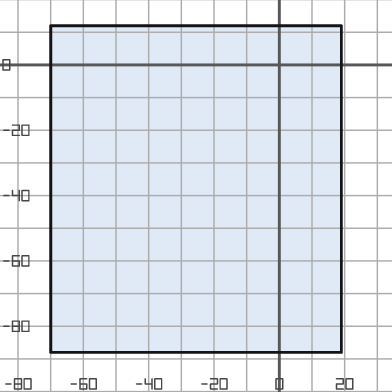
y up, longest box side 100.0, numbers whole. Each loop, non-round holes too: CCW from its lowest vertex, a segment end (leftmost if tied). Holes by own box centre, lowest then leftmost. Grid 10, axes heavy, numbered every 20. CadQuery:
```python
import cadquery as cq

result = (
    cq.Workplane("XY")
    .moveTo(-70.0, -88.0)
    .lineTo(19.0, -88.0)
    .lineTo(19.0, 12.0)
    .lineTo(-70.0, 12.0)
    .close()
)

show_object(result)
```